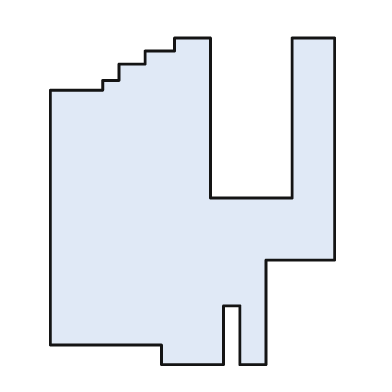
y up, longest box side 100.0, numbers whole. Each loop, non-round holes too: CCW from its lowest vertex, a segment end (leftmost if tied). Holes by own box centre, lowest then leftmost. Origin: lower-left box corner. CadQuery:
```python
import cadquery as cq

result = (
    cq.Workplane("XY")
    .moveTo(34.0, 0.0)
    .lineTo(53.0, 0.0)
    .lineTo(53.0, 18.0)
    .lineTo(58.0, 18.0)
    .lineTo(58.0, 0.0)
    .lineTo(66.0, 0.0)
    .lineTo(66.0, 32.0)
    .lineTo(87.0, 32.0)
    .lineTo(87.0, 100.0)
    .lineTo(74.0, 100.0)
    .lineTo(74.0, 51.0)
    .lineTo(49.0, 51.0)
    .lineTo(49.0, 100.0)
    .lineTo(38.0, 100.0)
    .lineTo(38.0, 96.0)
    .lineTo(29.0, 96.0)
    .lineTo(29.0, 92.0)
    .lineTo(21.0, 92.0)
    .lineTo(21.0, 87.0)
    .lineTo(16.0, 87.0)
    .lineTo(16.0, 84.0)
    .lineTo(0.0, 84.0)
    .lineTo(0.0, 6.0)
    .lineTo(34.0, 6.0)
    .close()
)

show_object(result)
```